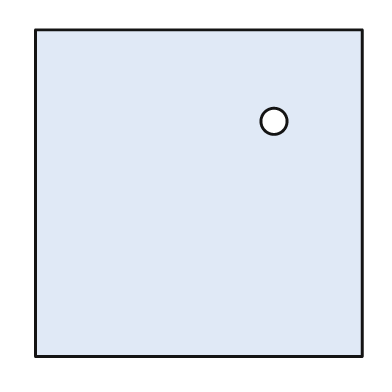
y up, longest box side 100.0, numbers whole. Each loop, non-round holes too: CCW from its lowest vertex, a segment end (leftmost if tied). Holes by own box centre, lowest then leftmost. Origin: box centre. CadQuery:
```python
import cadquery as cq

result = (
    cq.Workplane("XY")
    .moveTo(-50.0, -50.0)
    .lineTo(50.0, -50.0)
    .lineTo(50.0, 50.0)
    .lineTo(-50.0, 50.0)
    .close()
    .moveTo(23.0, 22.0)
    .circle(4.0)
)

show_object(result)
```